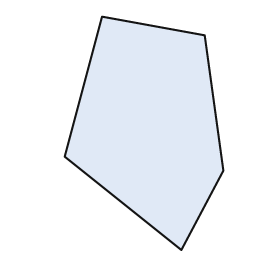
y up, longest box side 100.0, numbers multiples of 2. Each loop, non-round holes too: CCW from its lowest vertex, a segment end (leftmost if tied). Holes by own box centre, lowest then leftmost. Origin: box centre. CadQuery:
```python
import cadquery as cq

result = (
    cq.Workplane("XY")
    .moveTo(16.0, -50.0)
    .lineTo(34.0, -16.0)
    .lineTo(26.0, 42.0)
    .lineTo(-18.0, 50.0)
    .lineTo(-34.0, -10.0)
    .close()
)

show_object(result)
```